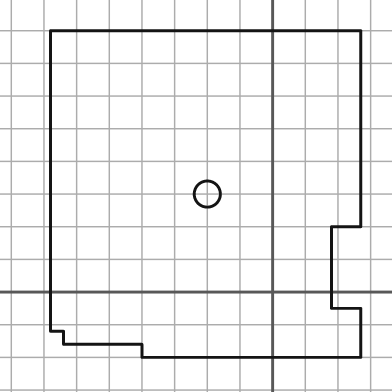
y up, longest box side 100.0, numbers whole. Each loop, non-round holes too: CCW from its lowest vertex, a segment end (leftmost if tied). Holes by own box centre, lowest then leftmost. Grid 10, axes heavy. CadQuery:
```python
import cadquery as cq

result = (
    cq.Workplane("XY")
    .moveTo(-40.0, -20.0)
    .lineTo(27.0, -20.0)
    .lineTo(27.0, -5.0)
    .lineTo(18.0, -5.0)
    .lineTo(18.0, 20.0)
    .lineTo(27.0, 20.0)
    .lineTo(27.0, 80.0)
    .lineTo(-68.0, 80.0)
    .lineTo(-68.0, -12.0)
    .lineTo(-64.0, -12.0)
    .lineTo(-64.0, -16.0)
    .lineTo(-40.0, -16.0)
    .close()
    .moveTo(-20.0, 30.0)
    .circle(4.0)
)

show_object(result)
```